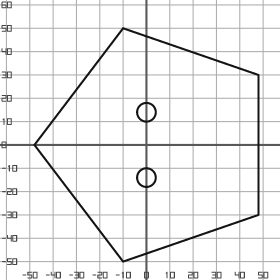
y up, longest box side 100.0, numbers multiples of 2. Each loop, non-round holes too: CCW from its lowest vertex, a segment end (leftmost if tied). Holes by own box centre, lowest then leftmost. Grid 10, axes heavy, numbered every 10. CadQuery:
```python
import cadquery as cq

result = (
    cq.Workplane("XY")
    .moveTo(-10.0, -50.0)
    .lineTo(48.0, -30.0)
    .lineTo(48.0, 30.0)
    .lineTo(-10.0, 50.0)
    .lineTo(-48.0, 0.0)
    .close()
    .moveTo(0.0, -14.0)
    .circle(4.0)
    .moveTo(0.0, 14.0)
    .circle(4.0)
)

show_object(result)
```